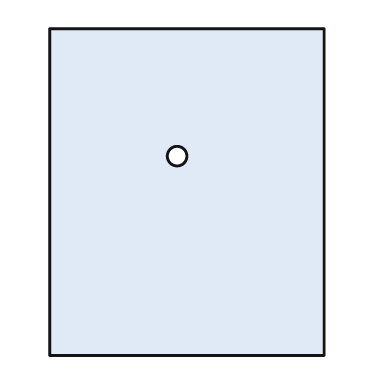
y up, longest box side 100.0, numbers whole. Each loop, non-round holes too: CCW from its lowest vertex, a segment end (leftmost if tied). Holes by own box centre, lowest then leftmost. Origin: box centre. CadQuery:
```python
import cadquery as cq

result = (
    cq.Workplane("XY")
    .moveTo(-42.0, -50.0)
    .lineTo(42.0, -50.0)
    .lineTo(42.0, 50.0)
    .lineTo(-42.0, 50.0)
    .close()
    .moveTo(-3.0, 11.0)
    .circle(3.0)
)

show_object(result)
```